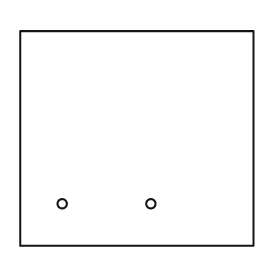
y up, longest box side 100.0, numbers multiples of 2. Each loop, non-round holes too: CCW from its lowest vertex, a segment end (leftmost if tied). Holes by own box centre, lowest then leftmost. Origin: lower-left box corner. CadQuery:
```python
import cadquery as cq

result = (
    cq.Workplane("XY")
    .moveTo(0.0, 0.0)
    .lineTo(100.0, 0.0)
    .lineTo(100.0, 92.0)
    .lineTo(0.0, 92.0)
    .close()
    .moveTo(18.0, 18.0)
    .circle(2.0)
    .moveTo(56.0, 18.0)
    .circle(2.0)
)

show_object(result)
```